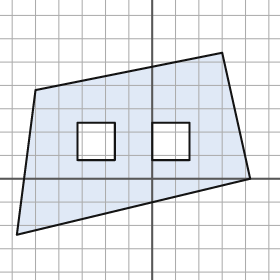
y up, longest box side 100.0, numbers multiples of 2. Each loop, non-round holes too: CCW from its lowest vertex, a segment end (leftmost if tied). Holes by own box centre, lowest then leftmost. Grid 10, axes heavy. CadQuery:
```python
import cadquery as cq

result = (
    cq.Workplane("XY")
    .moveTo(-58.0, -24.0)
    .lineTo(42.0, 0.0)
    .lineTo(30.0, 54.0)
    .lineTo(-50.0, 38.0)
    .close()
    .moveTo(-32.0, 8.0)
    .lineTo(-16.0, 8.0)
    .lineTo(-16.0, 24.0)
    .lineTo(-32.0, 24.0)
    .close()
    .moveTo(0.0, 8.0)
    .lineTo(16.0, 8.0)
    .lineTo(16.0, 24.0)
    .lineTo(0.0, 24.0)
    .close()
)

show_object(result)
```